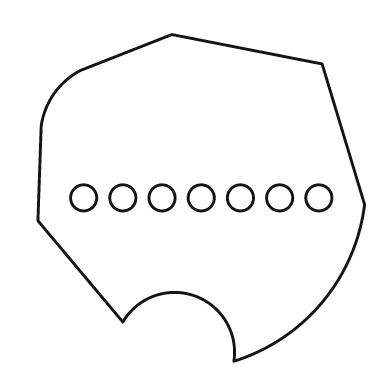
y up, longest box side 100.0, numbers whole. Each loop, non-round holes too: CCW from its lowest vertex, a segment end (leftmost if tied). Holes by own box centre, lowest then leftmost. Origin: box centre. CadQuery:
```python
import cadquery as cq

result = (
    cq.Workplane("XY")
    .moveTo(10.0, -50.0)
    .threePointArc((37.0, -32.0), (50.0, -2.0))
    .lineTo(37.0, 41.0)
    .lineTo(-9.0, 50.0)
    .lineTo(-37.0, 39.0)
    .threePointArc((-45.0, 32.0), (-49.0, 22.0))
    .lineTo(-50.0, -7.0)
    .lineTo(-24.0, -38.0)
    .threePointArc((-2.0, -30.0), (10.0, -50.0))
    .close()
    .moveTo(-36.0, 0.0)
    .circle(4.0)
    .moveTo(-24.0, 0.0)
    .circle(4.0)
    .moveTo(-12.0, 0.0)
    .circle(4.0)
    .moveTo(0.0, 0.0)
    .circle(4.0)
    .moveTo(12.0, 0.0)
    .circle(4.0)
    .moveTo(24.0, 0.0)
    .circle(4.0)
    .moveTo(36.0, 0.0)
    .circle(4.0)
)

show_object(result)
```